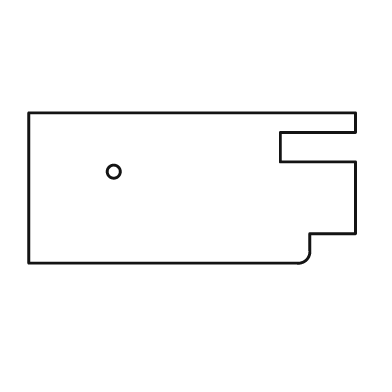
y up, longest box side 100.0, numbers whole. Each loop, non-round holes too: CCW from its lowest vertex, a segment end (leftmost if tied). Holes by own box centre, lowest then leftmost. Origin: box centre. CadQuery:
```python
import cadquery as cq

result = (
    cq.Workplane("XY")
    .moveTo(-50.0, -23.0)
    .lineTo(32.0, -23.0)
    .threePointArc((35.0, -22.0), (36.0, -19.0))
    .lineTo(36.0, -14.0)
    .lineTo(50.0, -14.0)
    .lineTo(50.0, 8.0)
    .lineTo(27.0, 8.0)
    .lineTo(27.0, 17.0)
    .lineTo(50.0, 17.0)
    .lineTo(50.0, 23.0)
    .lineTo(-50.0, 23.0)
    .close()
    .moveTo(-24.0, 5.0)
    .circle(2.0)
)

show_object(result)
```